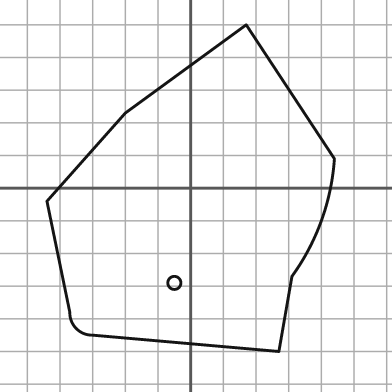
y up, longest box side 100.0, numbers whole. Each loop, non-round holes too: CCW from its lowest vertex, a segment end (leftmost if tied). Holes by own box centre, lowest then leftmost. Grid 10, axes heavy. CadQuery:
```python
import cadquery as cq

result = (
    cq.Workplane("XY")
    .moveTo(27.0, -50.0)
    .lineTo(31.0, -27.0)
    .threePointArc((40.0, -10.0), (44.0, 9.0))
    .lineTo(17.0, 50.0)
    .lineTo(-20.0, 23.0)
    .lineTo(-44.0, -4.0)
    .lineTo(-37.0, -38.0)
    .threePointArc((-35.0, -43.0), (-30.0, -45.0))
    .close()
    .moveTo(-5.0, -29.0)
    .circle(2.0)
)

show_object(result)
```